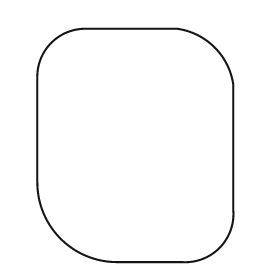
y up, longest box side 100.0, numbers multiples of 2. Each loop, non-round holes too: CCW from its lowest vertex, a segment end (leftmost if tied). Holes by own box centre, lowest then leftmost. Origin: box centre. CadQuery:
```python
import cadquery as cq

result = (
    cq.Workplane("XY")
    .moveTo(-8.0, -50.0)
    .lineTo(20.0, -50.0)
    .threePointArc((36.0, -44.0), (42.0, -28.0))
    .lineTo(42.0, 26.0)
    .threePointArc((34.0, 42.0), (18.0, 50.0))
    .lineTo(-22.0, 50.0)
    .threePointArc((-36.0, 44.0), (-42.0, 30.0))
    .lineTo(-42.0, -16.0)
    .threePointArc((-32.0, -40.0), (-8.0, -50.0))
    .close()
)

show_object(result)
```